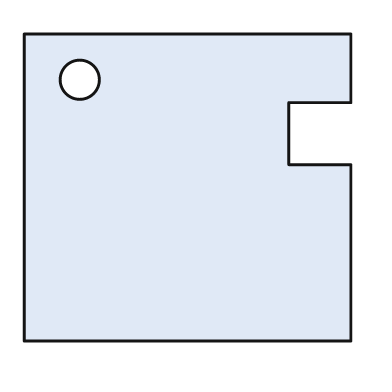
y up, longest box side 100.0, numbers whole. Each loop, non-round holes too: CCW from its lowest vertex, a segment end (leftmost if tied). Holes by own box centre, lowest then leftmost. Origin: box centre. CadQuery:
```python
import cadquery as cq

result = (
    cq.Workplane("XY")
    .moveTo(-50.0, -47.0)
    .lineTo(50.0, -47.0)
    .lineTo(50.0, 7.0)
    .lineTo(31.0, 7.0)
    .lineTo(31.0, 26.0)
    .lineTo(50.0, 26.0)
    .lineTo(50.0, 47.0)
    .lineTo(-50.0, 47.0)
    .close()
    .moveTo(-33.0, 33.0)
    .circle(6.0)
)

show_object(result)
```